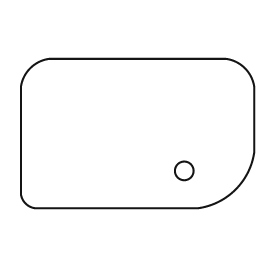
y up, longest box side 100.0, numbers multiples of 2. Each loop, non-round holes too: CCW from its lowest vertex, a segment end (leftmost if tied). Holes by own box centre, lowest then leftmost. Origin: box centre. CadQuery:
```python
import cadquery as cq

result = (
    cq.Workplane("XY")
    .moveTo(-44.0, -32.0)
    .lineTo(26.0, -32.0)
    .threePointArc((42.0, -24.0), (50.0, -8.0))
    .lineTo(50.0, 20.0)
    .threePointArc((46.0, 28.0), (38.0, 32.0))
    .lineTo(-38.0, 32.0)
    .threePointArc((-46.0, 28.0), (-50.0, 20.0))
    .lineTo(-50.0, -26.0)
    .threePointArc((-48.0, -30.0), (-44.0, -32.0))
    .close()
    .moveTo(20.0, -16.0)
    .circle(4.0)
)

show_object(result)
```